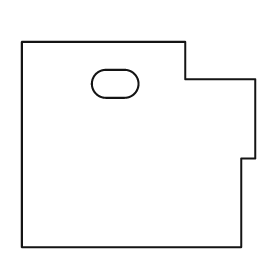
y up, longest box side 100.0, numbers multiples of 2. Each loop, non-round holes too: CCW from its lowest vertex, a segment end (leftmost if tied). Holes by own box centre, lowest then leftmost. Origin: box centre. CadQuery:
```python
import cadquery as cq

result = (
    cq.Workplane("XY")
    .moveTo(-50.0, -44.0)
    .lineTo(44.0, -44.0)
    .lineTo(44.0, -6.0)
    .lineTo(50.0, -6.0)
    .lineTo(50.0, 28.0)
    .lineTo(20.0, 28.0)
    .lineTo(20.0, 44.0)
    .lineTo(-50.0, 44.0)
    .close()
    .moveTo(-14.0, 20.0)
    .lineTo(-6.0, 20.0)
    .threePointArc((0.0, 26.0), (-6.0, 32.0))
    .lineTo(-14.0, 32.0)
    .threePointArc((-20.0, 26.0), (-14.0, 20.0))
    .close()
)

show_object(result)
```